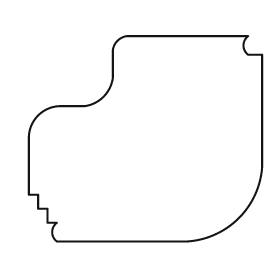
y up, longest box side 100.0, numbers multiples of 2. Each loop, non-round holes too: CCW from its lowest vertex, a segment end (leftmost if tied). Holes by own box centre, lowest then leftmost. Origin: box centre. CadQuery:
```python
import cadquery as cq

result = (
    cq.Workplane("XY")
    .moveTo(-38.0, -44.0)
    .lineTo(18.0, -44.0)
    .threePointArc((40.0, -34.0), (50.0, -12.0))
    .lineTo(50.0, 36.0)
    .lineTo(44.0, 36.0)
    .threePointArc((42.0, 40.0), (44.0, 44.0))
    .lineTo(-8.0, 44.0)
    .threePointArc((-12.0, 42.0), (-14.0, 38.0))
    .lineTo(-14.0, 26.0)
    .threePointArc((-18.0, 18.0), (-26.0, 14.0))
    .lineTo(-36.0, 14.0)
    .threePointArc((-46.0, 10.0), (-50.0, 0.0))
    .lineTo(-50.0, -24.0)
    .lineTo(-46.0, -24.0)
    .lineTo(-46.0, -30.0)
    .lineTo(-42.0, -30.0)
    .lineTo(-42.0, -36.0)
    .lineTo(-38.0, -36.0)
    .threePointArc((-40.0, -40.0), (-38.0, -44.0))
    .close()
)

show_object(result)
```